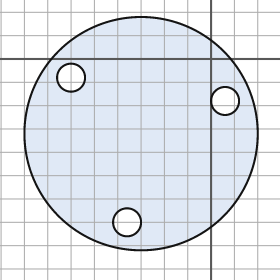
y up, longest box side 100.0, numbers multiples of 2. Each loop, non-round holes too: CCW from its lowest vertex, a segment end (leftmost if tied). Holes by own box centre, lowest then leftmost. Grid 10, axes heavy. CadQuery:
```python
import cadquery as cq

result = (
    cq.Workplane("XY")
    .moveTo(-30.0, -32.0)
    .circle(50.0)
    .moveTo(-36.0, -70.0)
    .circle(6.0)
    .moveTo(6.0, -18.0)
    .circle(6.0)
    .moveTo(-60.0, -8.0)
    .circle(6.0)
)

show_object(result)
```